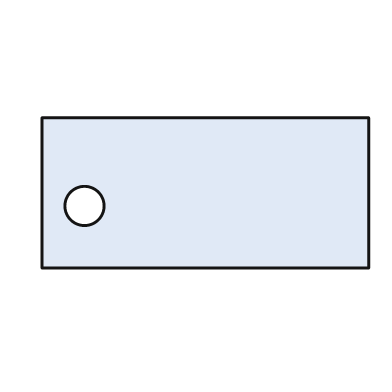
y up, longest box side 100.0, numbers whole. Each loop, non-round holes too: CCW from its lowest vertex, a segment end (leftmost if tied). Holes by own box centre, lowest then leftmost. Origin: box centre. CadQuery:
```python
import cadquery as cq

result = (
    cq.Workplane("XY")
    .moveTo(-50.0, -23.0)
    .lineTo(50.0, -23.0)
    .lineTo(50.0, 23.0)
    .lineTo(-50.0, 23.0)
    .close()
    .moveTo(-37.0, -4.0)
    .circle(6.0)
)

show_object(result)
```